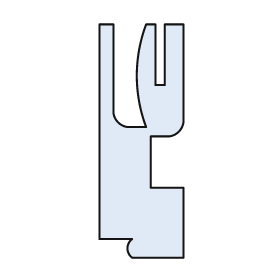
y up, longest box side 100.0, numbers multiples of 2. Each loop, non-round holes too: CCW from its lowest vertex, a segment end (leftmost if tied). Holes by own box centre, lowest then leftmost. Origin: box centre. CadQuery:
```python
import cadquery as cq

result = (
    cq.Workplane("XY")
    .moveTo(-4.0, -50.0)
    .lineTo(18.0, -50.0)
    .lineTo(18.0, -20.0)
    .lineTo(4.0, -20.0)
    .lineTo(4.0, 2.0)
    .lineTo(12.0, 2.0)
    .threePointArc((16.0, 4.0), (18.0, 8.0))
    .lineTo(18.0, 50.0)
    .lineTo(10.0, 50.0)
    .lineTo(10.0, 24.0)
    .lineTo(6.0, 24.0)
    .lineTo(6.0, 50.0)
    .lineTo(2.0, 50.0)
    .threePointArc((-2.0, 28.0), (2.0, 6.0))
    .lineTo(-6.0, 6.0)
    .threePointArc((-10.0, 8.0), (-12.0, 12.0))
    .lineTo(-12.0, 50.0)
    .lineTo(-18.0, 50.0)
    .lineTo(-18.0, -42.0)
    .lineTo(-4.0, -42.0)
    .threePointArc((-6.0, -46.0), (-4.0, -50.0))
    .close()
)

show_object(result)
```